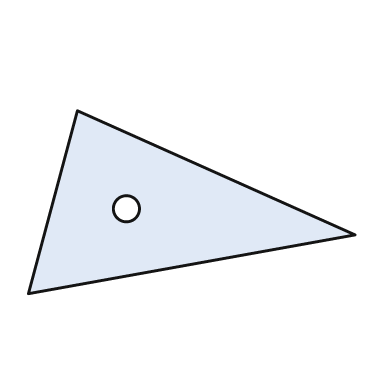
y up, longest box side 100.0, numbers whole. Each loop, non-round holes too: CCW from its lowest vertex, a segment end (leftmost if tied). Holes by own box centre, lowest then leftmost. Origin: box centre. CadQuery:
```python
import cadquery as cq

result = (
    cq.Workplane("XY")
    .moveTo(-50.0, -28.0)
    .lineTo(50.0, -10.0)
    .lineTo(-35.0, 28.0)
    .close()
    .moveTo(-20.0, -2.0)
    .circle(4.0)
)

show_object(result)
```